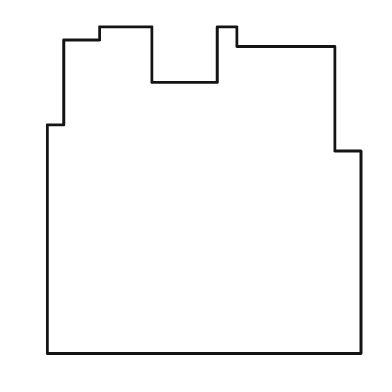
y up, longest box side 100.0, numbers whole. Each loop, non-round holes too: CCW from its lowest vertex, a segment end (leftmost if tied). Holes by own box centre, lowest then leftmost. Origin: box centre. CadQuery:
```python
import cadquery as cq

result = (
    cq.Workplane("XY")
    .moveTo(-48.0, -50.0)
    .lineTo(48.0, -50.0)
    .lineTo(48.0, 12.0)
    .lineTo(40.0, 12.0)
    .lineTo(40.0, 44.0)
    .lineTo(10.0, 44.0)
    .lineTo(10.0, 50.0)
    .lineTo(4.0, 50.0)
    .lineTo(4.0, 33.0)
    .lineTo(-16.0, 33.0)
    .lineTo(-16.0, 50.0)
    .lineTo(-32.0, 50.0)
    .lineTo(-32.0, 46.0)
    .lineTo(-43.0, 46.0)
    .lineTo(-43.0, 20.0)
    .lineTo(-48.0, 20.0)
    .close()
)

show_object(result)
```